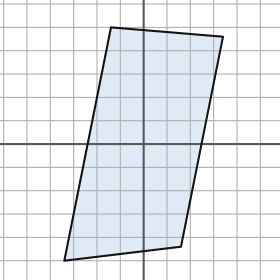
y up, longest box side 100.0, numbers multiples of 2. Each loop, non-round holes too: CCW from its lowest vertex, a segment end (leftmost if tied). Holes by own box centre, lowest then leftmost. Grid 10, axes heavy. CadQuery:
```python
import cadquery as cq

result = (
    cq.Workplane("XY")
    .moveTo(-34.0, -50.0)
    .lineTo(16.0, -44.0)
    .lineTo(34.0, 46.0)
    .lineTo(-14.0, 50.0)
    .close()
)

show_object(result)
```